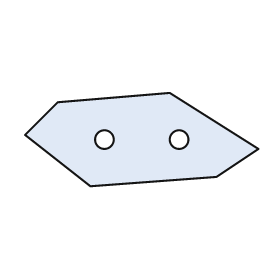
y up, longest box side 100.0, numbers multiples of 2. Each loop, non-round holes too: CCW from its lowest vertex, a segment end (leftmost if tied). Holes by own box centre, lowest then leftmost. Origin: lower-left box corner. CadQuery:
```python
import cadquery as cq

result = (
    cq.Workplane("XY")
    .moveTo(28.0, 0.0)
    .lineTo(82.0, 4.0)
    .lineTo(100.0, 16.0)
    .lineTo(62.0, 40.0)
    .lineTo(14.0, 36.0)
    .lineTo(0.0, 22.0)
    .close()
    .moveTo(34.0, 20.0)
    .circle(4.0)
    .moveTo(66.0, 20.0)
    .circle(4.0)
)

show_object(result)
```